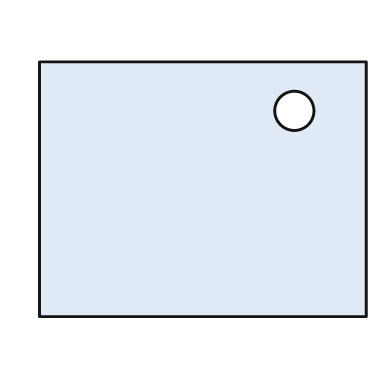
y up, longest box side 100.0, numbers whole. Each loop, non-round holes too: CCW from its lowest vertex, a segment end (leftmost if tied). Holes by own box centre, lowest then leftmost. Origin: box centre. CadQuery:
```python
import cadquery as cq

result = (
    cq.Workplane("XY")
    .moveTo(-50.0, -39.0)
    .lineTo(50.0, -39.0)
    .lineTo(50.0, 39.0)
    .lineTo(-50.0, 39.0)
    .close()
    .moveTo(28.0, 24.0)
    .circle(6.0)
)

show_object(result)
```